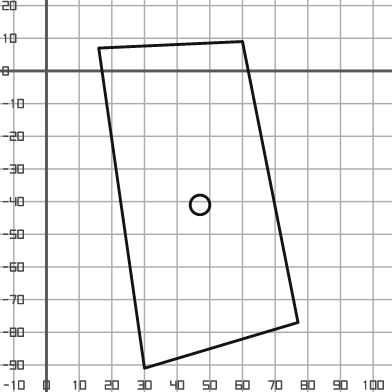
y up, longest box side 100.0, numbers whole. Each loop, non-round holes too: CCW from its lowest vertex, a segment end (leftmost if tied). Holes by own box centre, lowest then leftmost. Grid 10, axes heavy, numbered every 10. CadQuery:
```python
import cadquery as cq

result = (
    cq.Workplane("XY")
    .moveTo(30.0, -91.0)
    .lineTo(77.0, -77.0)
    .lineTo(60.0, 9.0)
    .lineTo(16.0, 7.0)
    .close()
    .moveTo(47.0, -41.0)
    .circle(3.0)
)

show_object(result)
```